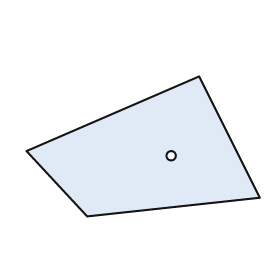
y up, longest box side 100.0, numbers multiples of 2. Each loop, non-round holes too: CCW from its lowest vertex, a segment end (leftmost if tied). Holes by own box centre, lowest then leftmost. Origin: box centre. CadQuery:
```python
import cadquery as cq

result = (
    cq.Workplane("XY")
    .moveTo(-24.0, -30.0)
    .lineTo(50.0, -22.0)
    .lineTo(24.0, 30.0)
    .lineTo(-50.0, -2.0)
    .close()
    .moveTo(12.0, -4.0)
    .circle(2.0)
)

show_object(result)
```